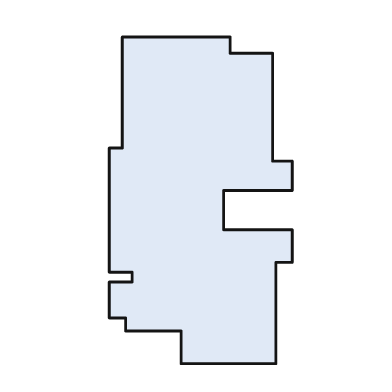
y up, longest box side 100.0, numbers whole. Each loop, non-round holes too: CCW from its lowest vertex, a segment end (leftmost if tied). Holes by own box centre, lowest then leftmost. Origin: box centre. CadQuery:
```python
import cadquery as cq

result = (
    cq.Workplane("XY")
    .moveTo(-6.0, -50.0)
    .lineTo(23.0, -50.0)
    .lineTo(23.0, -19.0)
    .lineTo(28.0, -19.0)
    .lineTo(28.0, -9.0)
    .lineTo(7.0, -9.0)
    .lineTo(7.0, 3.0)
    .lineTo(28.0, 3.0)
    .lineTo(28.0, 12.0)
    .lineTo(22.0, 12.0)
    .lineTo(22.0, 45.0)
    .lineTo(9.0, 45.0)
    .lineTo(9.0, 50.0)
    .lineTo(-24.0, 50.0)
    .lineTo(-24.0, 16.0)
    .lineTo(-28.0, 16.0)
    .lineTo(-28.0, -22.0)
    .lineTo(-21.0, -22.0)
    .lineTo(-21.0, -25.0)
    .lineTo(-28.0, -25.0)
    .lineTo(-28.0, -36.0)
    .lineTo(-23.0, -36.0)
    .lineTo(-23.0, -40.0)
    .lineTo(-6.0, -40.0)
    .close()
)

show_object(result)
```